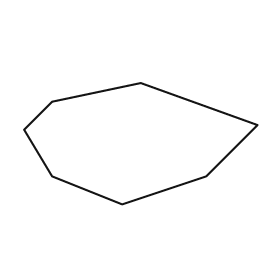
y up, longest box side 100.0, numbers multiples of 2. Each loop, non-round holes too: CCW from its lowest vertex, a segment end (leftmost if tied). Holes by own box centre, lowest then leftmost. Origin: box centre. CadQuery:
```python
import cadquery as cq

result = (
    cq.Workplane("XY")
    .moveTo(-8.0, -26.0)
    .lineTo(28.0, -14.0)
    .lineTo(50.0, 8.0)
    .lineTo(0.0, 26.0)
    .lineTo(-38.0, 18.0)
    .lineTo(-50.0, 6.0)
    .lineTo(-38.0, -14.0)
    .close()
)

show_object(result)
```